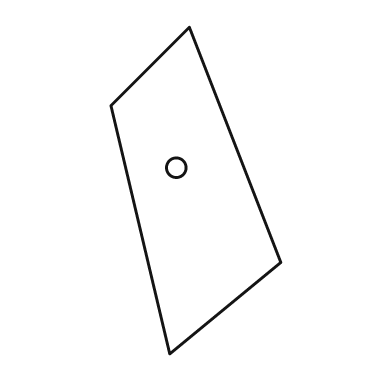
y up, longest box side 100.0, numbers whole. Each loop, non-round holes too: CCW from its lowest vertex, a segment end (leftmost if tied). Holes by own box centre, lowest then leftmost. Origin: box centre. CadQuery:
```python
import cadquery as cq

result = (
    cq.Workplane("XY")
    .moveTo(-8.0, -50.0)
    .lineTo(26.0, -22.0)
    .lineTo(-2.0, 50.0)
    .lineTo(-26.0, 26.0)
    .close()
    .moveTo(-6.0, 7.0)
    .circle(3.0)
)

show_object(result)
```